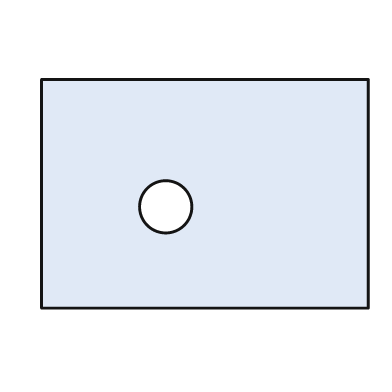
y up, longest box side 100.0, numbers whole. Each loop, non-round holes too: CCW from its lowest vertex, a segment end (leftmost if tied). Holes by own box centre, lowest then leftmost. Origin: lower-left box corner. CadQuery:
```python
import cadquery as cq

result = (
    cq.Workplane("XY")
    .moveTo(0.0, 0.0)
    .lineTo(100.0, 0.0)
    .lineTo(100.0, 70.0)
    .lineTo(0.0, 70.0)
    .close()
    .moveTo(38.0, 31.0)
    .circle(8.0)
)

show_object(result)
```